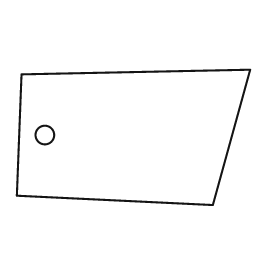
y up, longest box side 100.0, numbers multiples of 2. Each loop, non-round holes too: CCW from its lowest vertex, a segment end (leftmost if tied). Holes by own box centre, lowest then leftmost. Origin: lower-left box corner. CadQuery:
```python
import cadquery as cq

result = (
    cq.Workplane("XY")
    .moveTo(84.0, 0.0)
    .lineTo(100.0, 58.0)
    .lineTo(2.0, 56.0)
    .lineTo(0.0, 4.0)
    .close()
    .moveTo(12.0, 30.0)
    .circle(4.0)
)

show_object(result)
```